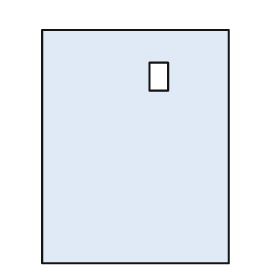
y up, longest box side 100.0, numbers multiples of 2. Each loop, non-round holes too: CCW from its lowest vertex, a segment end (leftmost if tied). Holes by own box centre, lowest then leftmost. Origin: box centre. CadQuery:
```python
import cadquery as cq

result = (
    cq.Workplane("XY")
    .moveTo(-40.0, -50.0)
    .lineTo(40.0, -50.0)
    .lineTo(40.0, 50.0)
    .lineTo(-40.0, 50.0)
    .close()
    .moveTo(6.0, 24.0)
    .lineTo(14.0, 24.0)
    .lineTo(14.0, 36.0)
    .lineTo(6.0, 36.0)
    .close()
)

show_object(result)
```